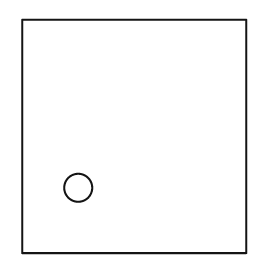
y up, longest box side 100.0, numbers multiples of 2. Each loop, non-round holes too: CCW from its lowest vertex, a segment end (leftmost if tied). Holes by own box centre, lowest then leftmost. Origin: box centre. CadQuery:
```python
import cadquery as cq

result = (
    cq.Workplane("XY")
    .moveTo(-48.0, -50.0)
    .lineTo(48.0, -50.0)
    .lineTo(48.0, 50.0)
    .lineTo(-48.0, 50.0)
    .close()
    .moveTo(-24.0, -22.0)
    .circle(6.0)
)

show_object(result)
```